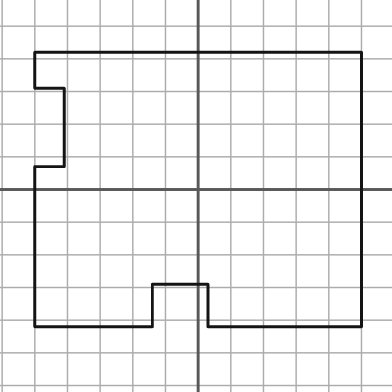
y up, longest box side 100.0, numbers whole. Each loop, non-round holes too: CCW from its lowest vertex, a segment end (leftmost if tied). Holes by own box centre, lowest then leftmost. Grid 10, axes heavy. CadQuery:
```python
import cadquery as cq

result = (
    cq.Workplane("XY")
    .moveTo(-50.0, -42.0)
    .lineTo(-14.0, -42.0)
    .lineTo(-14.0, -29.0)
    .lineTo(3.0, -29.0)
    .lineTo(3.0, -42.0)
    .lineTo(50.0, -42.0)
    .lineTo(50.0, 42.0)
    .lineTo(-50.0, 42.0)
    .lineTo(-50.0, 31.0)
    .lineTo(-41.0, 31.0)
    .lineTo(-41.0, 7.0)
    .lineTo(-50.0, 7.0)
    .close()
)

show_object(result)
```